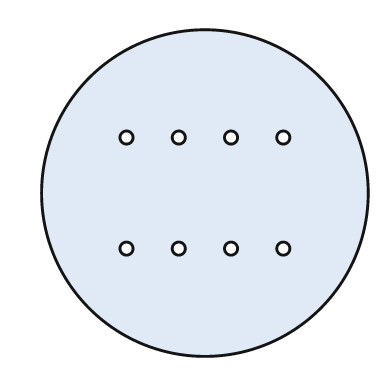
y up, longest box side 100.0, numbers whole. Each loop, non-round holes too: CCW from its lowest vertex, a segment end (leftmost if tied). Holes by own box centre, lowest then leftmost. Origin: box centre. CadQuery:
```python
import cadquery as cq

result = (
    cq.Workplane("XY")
    .moveTo(0.0, 0.0)
    .circle(50.0)
    .moveTo(-24.0, -17.0)
    .circle(2.0)
    .moveTo(-8.0, -17.0)
    .circle(2.0)
    .moveTo(8.0, -17.0)
    .circle(2.0)
    .moveTo(24.0, -17.0)
    .circle(2.0)
    .moveTo(-24.0, 17.0)
    .circle(2.0)
    .moveTo(-8.0, 17.0)
    .circle(2.0)
    .moveTo(8.0, 17.0)
    .circle(2.0)
    .moveTo(24.0, 17.0)
    .circle(2.0)
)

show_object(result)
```